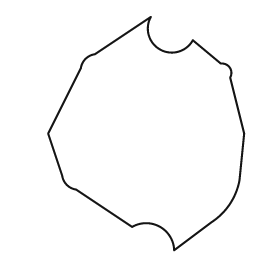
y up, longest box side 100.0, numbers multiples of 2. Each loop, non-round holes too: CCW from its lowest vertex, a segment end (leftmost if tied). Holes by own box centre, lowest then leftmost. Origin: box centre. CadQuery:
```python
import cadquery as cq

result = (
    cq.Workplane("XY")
    .moveTo(12.0, -50.0)
    .lineTo(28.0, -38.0)
    .threePointArc((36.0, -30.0), (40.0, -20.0))
    .lineTo(42.0, 0.0)
    .lineTo(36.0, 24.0)
    .threePointArc((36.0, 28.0), (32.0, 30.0))
    .lineTo(20.0, 40.0)
    .threePointArc((6.0, 36.0), (2.0, 50.0))
    .lineTo(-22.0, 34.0)
    .threePointArc((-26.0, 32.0), (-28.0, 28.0))
    .lineTo(-42.0, 0.0)
    .lineTo(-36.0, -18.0)
    .threePointArc((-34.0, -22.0), (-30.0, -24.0))
    .lineTo(-6.0, -40.0)
    .threePointArc((6.0, -40.0), (12.0, -50.0))
    .close()
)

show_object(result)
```